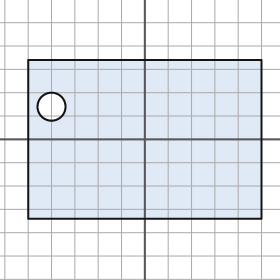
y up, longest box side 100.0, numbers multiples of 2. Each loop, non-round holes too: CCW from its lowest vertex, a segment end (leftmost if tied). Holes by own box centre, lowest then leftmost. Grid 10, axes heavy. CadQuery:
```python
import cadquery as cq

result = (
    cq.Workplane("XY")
    .moveTo(-50.0, -34.0)
    .lineTo(50.0, -34.0)
    .lineTo(50.0, 34.0)
    .lineTo(-50.0, 34.0)
    .close()
    .moveTo(-40.0, 14.0)
    .circle(6.0)
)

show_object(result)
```